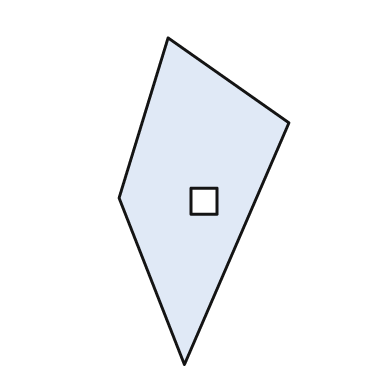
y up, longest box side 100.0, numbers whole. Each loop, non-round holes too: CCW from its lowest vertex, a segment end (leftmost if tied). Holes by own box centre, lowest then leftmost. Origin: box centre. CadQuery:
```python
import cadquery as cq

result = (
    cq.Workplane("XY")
    .moveTo(-6.0, -50.0)
    .lineTo(26.0, 24.0)
    .lineTo(-11.0, 50.0)
    .lineTo(-26.0, 1.0)
    .close()
    .moveTo(-4.0, -4.0)
    .lineTo(4.0, -4.0)
    .lineTo(4.0, 4.0)
    .lineTo(-4.0, 4.0)
    .close()
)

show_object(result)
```